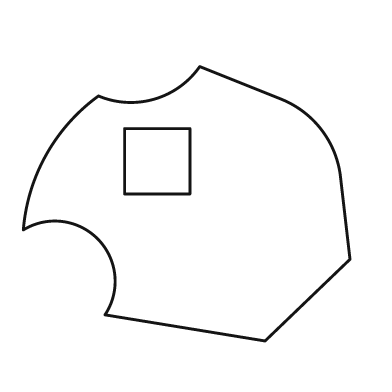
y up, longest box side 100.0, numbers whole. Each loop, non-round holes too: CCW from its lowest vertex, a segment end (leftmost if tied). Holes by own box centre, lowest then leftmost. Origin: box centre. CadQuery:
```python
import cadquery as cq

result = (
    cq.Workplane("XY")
    .moveTo(24.0, -42.0)
    .lineTo(50.0, -17.0)
    .lineTo(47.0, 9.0)
    .threePointArc((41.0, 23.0), (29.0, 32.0))
    .lineTo(4.0, 42.0)
    .threePointArc((-10.0, 32.0), (-27.0, 33.0))
    .threePointArc((-43.0, 15.0), (-50.0, -8.0))
    .threePointArc((-27.0, -11.0), (-25.0, -34.0))
    .close()
    .moveTo(-19.0, 3.0)
    .lineTo(1.0, 3.0)
    .lineTo(1.0, 23.0)
    .lineTo(-19.0, 23.0)
    .close()
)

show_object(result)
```